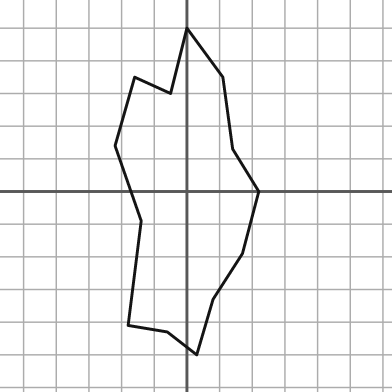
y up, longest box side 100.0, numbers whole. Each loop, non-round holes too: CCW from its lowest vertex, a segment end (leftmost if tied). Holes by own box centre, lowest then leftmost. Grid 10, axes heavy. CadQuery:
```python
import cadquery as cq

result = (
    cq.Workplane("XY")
    .moveTo(3.0, -50.0)
    .lineTo(8.0, -33.0)
    .lineTo(17.0, -19.0)
    .lineTo(22.0, 0.0)
    .lineTo(14.0, 13.0)
    .lineTo(11.0, 35.0)
    .lineTo(0.0, 50.0)
    .lineTo(-5.0, 30.0)
    .lineTo(-16.0, 35.0)
    .lineTo(-22.0, 14.0)
    .lineTo(-14.0, -9.0)
    .lineTo(-18.0, -41.0)
    .lineTo(-6.0, -43.0)
    .close()
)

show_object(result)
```